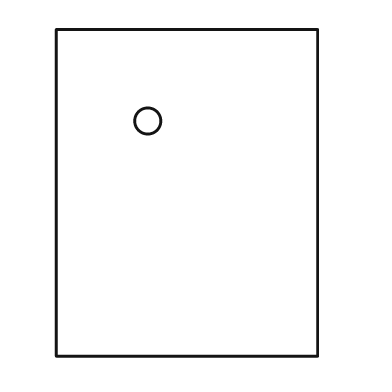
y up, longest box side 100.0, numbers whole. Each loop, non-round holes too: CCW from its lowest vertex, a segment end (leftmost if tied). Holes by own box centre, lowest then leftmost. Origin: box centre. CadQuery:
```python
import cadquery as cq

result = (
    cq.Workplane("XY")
    .moveTo(-40.0, -50.0)
    .lineTo(40.0, -50.0)
    .lineTo(40.0, 50.0)
    .lineTo(-40.0, 50.0)
    .close()
    .moveTo(-12.0, 22.0)
    .circle(4.0)
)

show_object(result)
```